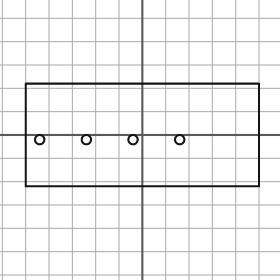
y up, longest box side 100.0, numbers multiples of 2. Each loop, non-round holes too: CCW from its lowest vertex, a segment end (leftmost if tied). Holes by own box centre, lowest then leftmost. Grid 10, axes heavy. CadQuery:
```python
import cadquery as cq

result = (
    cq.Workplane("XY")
    .moveTo(-50.0, -22.0)
    .lineTo(50.0, -22.0)
    .lineTo(50.0, 22.0)
    .lineTo(-50.0, 22.0)
    .close()
    .moveTo(-44.0, -2.0)
    .circle(2.0)
    .moveTo(-24.0, -2.0)
    .circle(2.0)
    .moveTo(-4.0, -2.0)
    .circle(2.0)
    .moveTo(16.0, -2.0)
    .circle(2.0)
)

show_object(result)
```